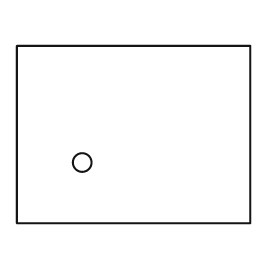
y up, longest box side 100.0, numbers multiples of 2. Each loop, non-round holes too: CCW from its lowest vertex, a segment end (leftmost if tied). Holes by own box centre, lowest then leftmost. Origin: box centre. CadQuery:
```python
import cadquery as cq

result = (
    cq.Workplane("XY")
    .moveTo(-50.0, -38.0)
    .lineTo(50.0, -38.0)
    .lineTo(50.0, 38.0)
    .lineTo(-50.0, 38.0)
    .close()
    .moveTo(-22.0, -12.0)
    .circle(4.0)
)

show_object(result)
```